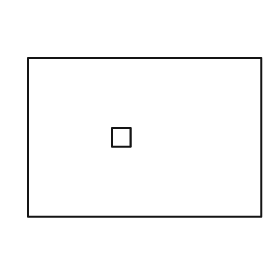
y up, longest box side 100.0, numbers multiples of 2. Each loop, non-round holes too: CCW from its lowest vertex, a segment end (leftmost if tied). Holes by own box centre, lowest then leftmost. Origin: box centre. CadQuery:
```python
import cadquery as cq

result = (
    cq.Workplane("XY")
    .moveTo(-50.0, -34.0)
    .lineTo(50.0, -34.0)
    .lineTo(50.0, 34.0)
    .lineTo(-50.0, 34.0)
    .close()
    .moveTo(-14.0, -4.0)
    .lineTo(-6.0, -4.0)
    .lineTo(-6.0, 4.0)
    .lineTo(-14.0, 4.0)
    .close()
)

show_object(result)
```